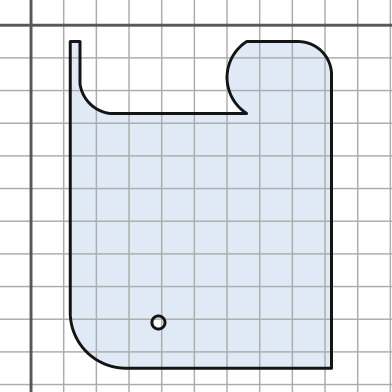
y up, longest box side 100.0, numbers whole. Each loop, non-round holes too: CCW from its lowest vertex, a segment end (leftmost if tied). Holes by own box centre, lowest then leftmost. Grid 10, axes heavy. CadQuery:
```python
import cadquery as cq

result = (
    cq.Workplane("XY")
    .moveTo(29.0, -105.0)
    .lineTo(92.0, -105.0)
    .lineTo(92.0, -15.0)
    .threePointArc((89.0, -8.0), (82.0, -5.0))
    .lineTo(66.0, -5.0)
    .threePointArc((60.0, -16.0), (66.0, -27.0))
    .lineTo(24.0, -27.0)
    .threePointArc((18.0, -24.0), (15.0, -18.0))
    .lineTo(15.0, -5.0)
    .lineTo(12.0, -5.0)
    .lineTo(12.0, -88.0)
    .threePointArc((17.0, -100.0), (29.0, -105.0))
    .close()
    .moveTo(39.0, -91.0)
    .circle(2.0)
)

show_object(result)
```